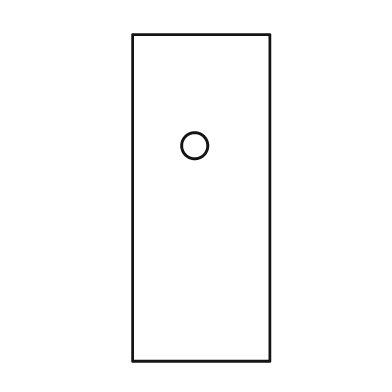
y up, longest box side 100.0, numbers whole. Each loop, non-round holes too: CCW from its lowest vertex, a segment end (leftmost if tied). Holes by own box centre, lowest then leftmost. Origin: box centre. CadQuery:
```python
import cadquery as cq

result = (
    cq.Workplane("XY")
    .moveTo(-21.0, -50.0)
    .lineTo(21.0, -50.0)
    .lineTo(21.0, 50.0)
    .lineTo(-21.0, 50.0)
    .close()
    .moveTo(-2.0, 16.0)
    .circle(4.0)
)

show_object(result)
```